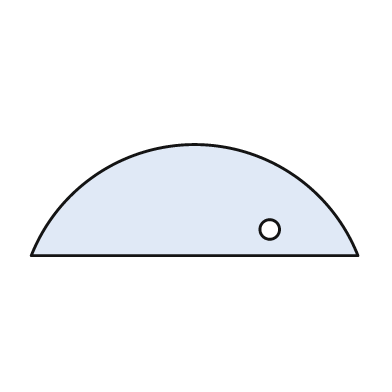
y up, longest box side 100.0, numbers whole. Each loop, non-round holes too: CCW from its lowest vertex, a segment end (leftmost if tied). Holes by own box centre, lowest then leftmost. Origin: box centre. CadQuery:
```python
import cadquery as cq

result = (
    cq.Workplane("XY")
    .moveTo(-50.0, -17.0)
    .lineTo(50.0, -17.0)
    .threePointArc((0.0, 17.0), (-50.0, -17.0))
    .close()
    .moveTo(23.0, -9.0)
    .circle(3.0)
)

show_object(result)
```